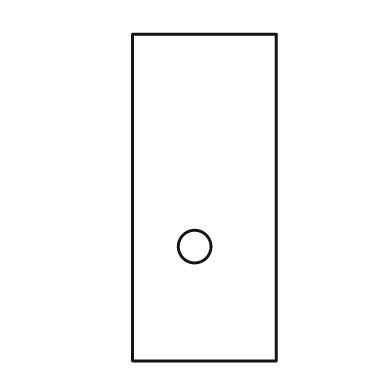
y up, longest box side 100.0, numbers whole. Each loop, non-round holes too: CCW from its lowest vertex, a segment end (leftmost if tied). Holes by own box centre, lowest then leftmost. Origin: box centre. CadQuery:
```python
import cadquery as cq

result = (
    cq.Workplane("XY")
    .moveTo(-22.0, -50.0)
    .lineTo(22.0, -50.0)
    .lineTo(22.0, 50.0)
    .lineTo(-22.0, 50.0)
    .close()
    .moveTo(-3.0, -15.0)
    .circle(5.0)
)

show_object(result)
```